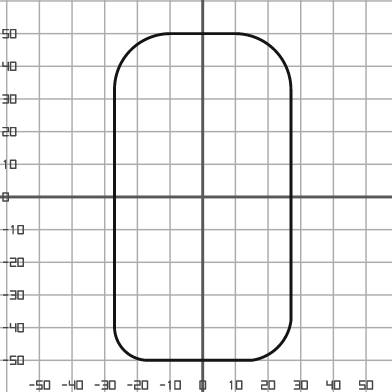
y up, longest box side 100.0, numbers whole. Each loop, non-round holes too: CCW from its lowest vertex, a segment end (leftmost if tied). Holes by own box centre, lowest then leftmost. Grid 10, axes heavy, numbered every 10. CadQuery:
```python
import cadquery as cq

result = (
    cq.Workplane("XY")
    .moveTo(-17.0, -50.0)
    .lineTo(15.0, -50.0)
    .threePointArc((23.0, -46.0), (27.0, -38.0))
    .lineTo(27.0, 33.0)
    .threePointArc((22.0, 45.0), (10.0, 50.0))
    .lineTo(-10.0, 50.0)
    .threePointArc((-22.0, 45.0), (-27.0, 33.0))
    .lineTo(-27.0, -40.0)
    .threePointArc((-24.0, -47.0), (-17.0, -50.0))
    .close()
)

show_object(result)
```